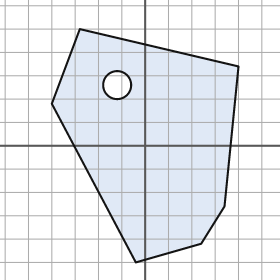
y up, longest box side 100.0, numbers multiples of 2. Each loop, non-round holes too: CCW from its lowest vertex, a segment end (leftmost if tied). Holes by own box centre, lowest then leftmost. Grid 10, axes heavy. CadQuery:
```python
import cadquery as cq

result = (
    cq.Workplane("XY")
    .moveTo(-4.0, -50.0)
    .lineTo(24.0, -42.0)
    .lineTo(34.0, -26.0)
    .lineTo(40.0, 34.0)
    .lineTo(-28.0, 50.0)
    .lineTo(-40.0, 18.0)
    .close()
    .moveTo(-12.0, 26.0)
    .circle(6.0)
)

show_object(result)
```